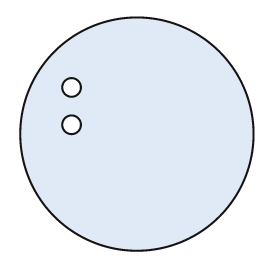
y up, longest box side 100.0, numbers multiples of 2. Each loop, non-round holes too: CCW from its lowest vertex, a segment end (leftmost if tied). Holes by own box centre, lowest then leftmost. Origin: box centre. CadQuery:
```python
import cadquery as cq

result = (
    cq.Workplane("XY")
    .moveTo(0.0, 0.0)
    .circle(50.0)
    .moveTo(-28.0, 4.0)
    .circle(4.0)
    .moveTo(-28.0, 20.0)
    .circle(4.0)
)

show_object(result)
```